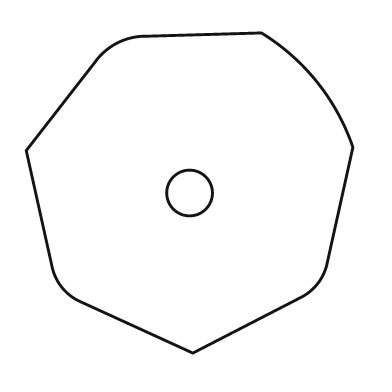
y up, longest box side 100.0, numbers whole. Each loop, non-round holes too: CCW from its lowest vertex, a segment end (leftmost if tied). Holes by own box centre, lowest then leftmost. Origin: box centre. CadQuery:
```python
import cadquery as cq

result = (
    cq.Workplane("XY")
    .moveTo(1.0, -49.0)
    .lineTo(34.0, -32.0)
    .threePointArc((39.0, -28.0), (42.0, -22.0))
    .lineTo(50.0, 14.0)
    .threePointArc((39.0, 34.0), (22.0, 49.0))
    .lineTo(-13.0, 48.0)
    .threePointArc((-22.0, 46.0), (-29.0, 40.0))
    .lineTo(-50.0, 13.0)
    .lineTo(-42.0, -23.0)
    .threePointArc((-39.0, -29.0), (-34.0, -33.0))
    .close()
    .moveTo(0.0, 0.0)
    .circle(7.0)
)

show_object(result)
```